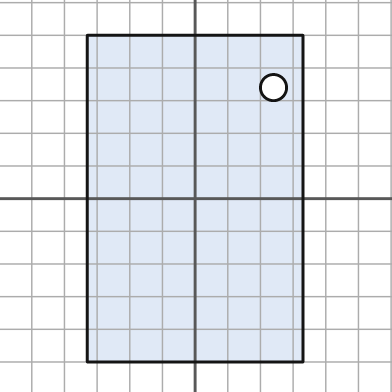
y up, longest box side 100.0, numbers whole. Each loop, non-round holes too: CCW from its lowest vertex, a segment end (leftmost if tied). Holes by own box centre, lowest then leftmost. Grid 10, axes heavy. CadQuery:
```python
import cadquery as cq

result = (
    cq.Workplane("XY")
    .moveTo(-33.0, -50.0)
    .lineTo(33.0, -50.0)
    .lineTo(33.0, 50.0)
    .lineTo(-33.0, 50.0)
    .close()
    .moveTo(24.0, 34.0)
    .circle(4.0)
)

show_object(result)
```